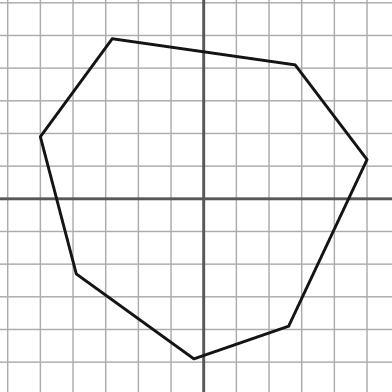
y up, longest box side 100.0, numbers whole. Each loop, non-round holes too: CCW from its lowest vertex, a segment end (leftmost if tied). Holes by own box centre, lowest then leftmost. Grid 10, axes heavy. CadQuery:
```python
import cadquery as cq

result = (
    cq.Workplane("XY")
    .moveTo(-3.0, -49.0)
    .lineTo(26.0, -39.0)
    .lineTo(50.0, 12.0)
    .lineTo(28.0, 41.0)
    .lineTo(-28.0, 49.0)
    .lineTo(-50.0, 19.0)
    .lineTo(-39.0, -23.0)
    .close()
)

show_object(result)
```